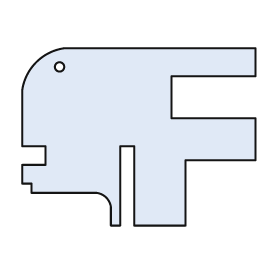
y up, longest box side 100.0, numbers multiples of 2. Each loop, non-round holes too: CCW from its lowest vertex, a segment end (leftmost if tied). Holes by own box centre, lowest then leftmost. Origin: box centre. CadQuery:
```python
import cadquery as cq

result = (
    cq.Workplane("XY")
    .moveTo(-12.0, -38.0)
    .lineTo(-8.0, -38.0)
    .lineTo(-8.0, -4.0)
    .lineTo(-2.0, -4.0)
    .lineTo(-2.0, -38.0)
    .lineTo(20.0, -38.0)
    .lineTo(20.0, -10.0)
    .lineTo(50.0, -10.0)
    .lineTo(50.0, 8.0)
    .lineTo(14.0, 8.0)
    .lineTo(14.0, 26.0)
    .lineTo(50.0, 26.0)
    .lineTo(50.0, 38.0)
    .lineTo(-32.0, 38.0)
    .threePointArc((-44.0, 32.0), (-50.0, 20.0))
    .lineTo(-50.0, -4.0)
    .lineTo(-40.0, -4.0)
    .lineTo(-40.0, -12.0)
    .lineTo(-50.0, -12.0)
    .lineTo(-50.0, -20.0)
    .lineTo(-46.0, -20.0)
    .lineTo(-46.0, -24.0)
    .lineTo(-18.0, -24.0)
    .threePointArc((-14.0, -26.0), (-12.0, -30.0))
    .close()
    .moveTo(-34.0, 30.0)
    .circle(2.0)
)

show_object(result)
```